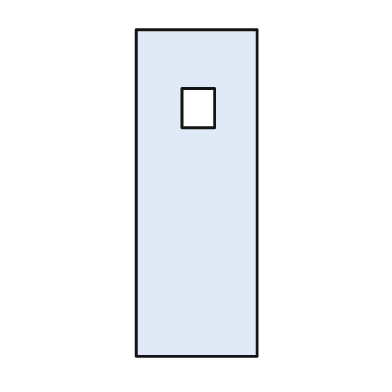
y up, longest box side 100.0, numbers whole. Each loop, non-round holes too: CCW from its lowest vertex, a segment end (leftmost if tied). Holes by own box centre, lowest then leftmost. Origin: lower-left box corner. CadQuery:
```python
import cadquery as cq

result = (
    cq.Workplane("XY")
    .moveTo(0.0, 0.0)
    .lineTo(37.0, 0.0)
    .lineTo(37.0, 100.0)
    .lineTo(0.0, 100.0)
    .close()
    .moveTo(14.0, 70.0)
    .lineTo(24.0, 70.0)
    .lineTo(24.0, 82.0)
    .lineTo(14.0, 82.0)
    .close()
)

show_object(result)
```